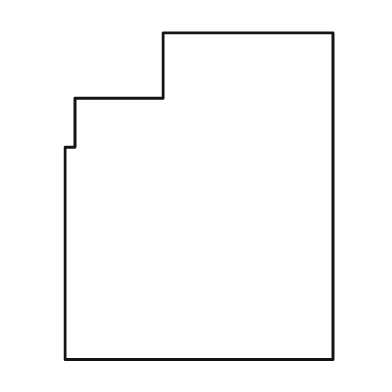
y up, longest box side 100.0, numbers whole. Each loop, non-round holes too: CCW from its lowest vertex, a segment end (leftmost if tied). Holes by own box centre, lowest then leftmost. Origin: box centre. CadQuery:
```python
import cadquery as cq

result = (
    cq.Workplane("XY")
    .moveTo(-41.0, -50.0)
    .lineTo(41.0, -50.0)
    .lineTo(41.0, 50.0)
    .lineTo(-11.0, 50.0)
    .lineTo(-11.0, 30.0)
    .lineTo(-38.0, 30.0)
    .lineTo(-38.0, 15.0)
    .lineTo(-41.0, 15.0)
    .close()
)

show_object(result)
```